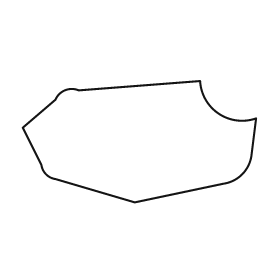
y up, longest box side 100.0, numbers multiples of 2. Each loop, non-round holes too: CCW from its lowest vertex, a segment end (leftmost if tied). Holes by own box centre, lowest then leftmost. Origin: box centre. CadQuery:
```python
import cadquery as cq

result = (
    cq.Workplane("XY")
    .moveTo(-2.0, -26.0)
    .lineTo(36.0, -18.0)
    .threePointArc((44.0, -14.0), (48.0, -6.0))
    .lineTo(50.0, 10.0)
    .threePointArc((34.0, 12.0), (26.0, 26.0))
    .lineTo(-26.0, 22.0)
    .threePointArc((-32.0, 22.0), (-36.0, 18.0))
    .lineTo(-50.0, 6.0)
    .lineTo(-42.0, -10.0)
    .threePointArc((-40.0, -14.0), (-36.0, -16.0))
    .close()
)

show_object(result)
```